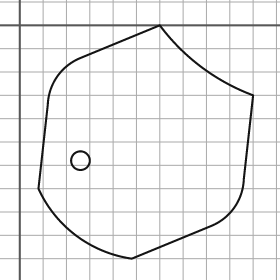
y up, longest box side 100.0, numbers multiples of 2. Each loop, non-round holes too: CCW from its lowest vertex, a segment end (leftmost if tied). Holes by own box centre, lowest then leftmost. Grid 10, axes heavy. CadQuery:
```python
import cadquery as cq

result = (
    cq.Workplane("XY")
    .moveTo(48.0, -100.0)
    .lineTo(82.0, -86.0)
    .threePointArc((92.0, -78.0), (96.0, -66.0))
    .lineTo(100.0, -30.0)
    .threePointArc((78.0, -18.0), (60.0, 0.0))
    .lineTo(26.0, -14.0)
    .threePointArc((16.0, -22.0), (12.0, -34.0))
    .lineTo(8.0, -70.0)
    .threePointArc((24.0, -90.0), (48.0, -100.0))
    .close()
    .moveTo(26.0, -58.0)
    .circle(4.0)
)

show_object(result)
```